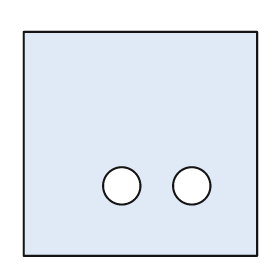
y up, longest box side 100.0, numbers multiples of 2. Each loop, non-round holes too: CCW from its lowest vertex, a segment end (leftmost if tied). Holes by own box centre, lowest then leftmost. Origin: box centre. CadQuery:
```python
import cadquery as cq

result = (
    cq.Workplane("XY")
    .moveTo(-50.0, -48.0)
    .lineTo(50.0, -48.0)
    .lineTo(50.0, 48.0)
    .lineTo(-50.0, 48.0)
    .close()
    .moveTo(-8.0, -18.0)
    .circle(8.0)
    .moveTo(22.0, -18.0)
    .circle(8.0)
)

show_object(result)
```